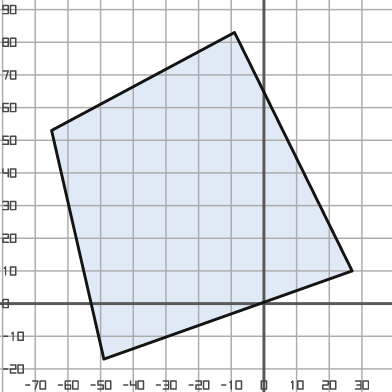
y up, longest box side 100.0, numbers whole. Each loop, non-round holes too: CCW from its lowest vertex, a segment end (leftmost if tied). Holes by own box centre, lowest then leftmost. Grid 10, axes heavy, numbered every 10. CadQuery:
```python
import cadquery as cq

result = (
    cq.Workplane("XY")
    .moveTo(-49.0, -17.0)
    .lineTo(27.0, 10.0)
    .lineTo(-9.0, 83.0)
    .lineTo(-65.0, 53.0)
    .close()
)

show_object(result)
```